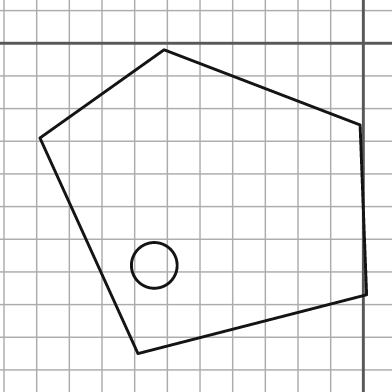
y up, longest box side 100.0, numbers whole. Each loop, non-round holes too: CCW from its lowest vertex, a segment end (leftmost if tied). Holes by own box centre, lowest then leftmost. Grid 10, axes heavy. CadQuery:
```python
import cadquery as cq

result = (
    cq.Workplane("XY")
    .moveTo(-69.0, -95.0)
    .lineTo(1.0, -77.0)
    .lineTo(-1.0, -25.0)
    .lineTo(-61.0, -2.0)
    .lineTo(-99.0, -29.0)
    .close()
    .moveTo(-64.0, -68.0)
    .circle(7.0)
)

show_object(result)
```